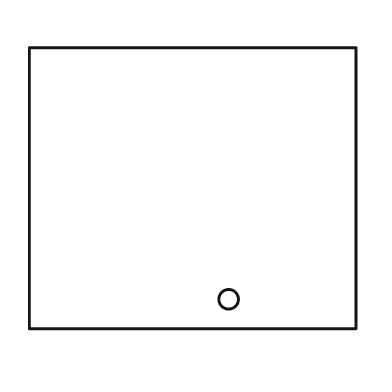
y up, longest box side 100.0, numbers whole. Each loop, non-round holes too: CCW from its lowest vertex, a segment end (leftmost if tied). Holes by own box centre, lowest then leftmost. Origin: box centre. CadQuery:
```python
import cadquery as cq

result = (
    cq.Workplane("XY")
    .moveTo(-50.0, -43.0)
    .lineTo(50.0, -43.0)
    .lineTo(50.0, 43.0)
    .lineTo(-50.0, 43.0)
    .close()
    .moveTo(11.0, -34.0)
    .circle(3.0)
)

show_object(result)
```